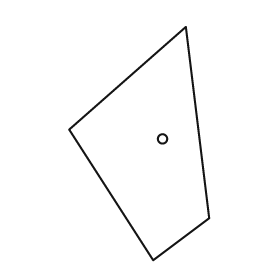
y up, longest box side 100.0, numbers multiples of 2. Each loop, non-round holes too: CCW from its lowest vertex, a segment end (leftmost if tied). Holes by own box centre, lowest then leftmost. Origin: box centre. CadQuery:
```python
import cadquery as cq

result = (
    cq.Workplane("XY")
    .moveTo(6.0, -50.0)
    .lineTo(30.0, -32.0)
    .lineTo(20.0, 50.0)
    .lineTo(-30.0, 6.0)
    .close()
    .moveTo(10.0, 2.0)
    .circle(2.0)
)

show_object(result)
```